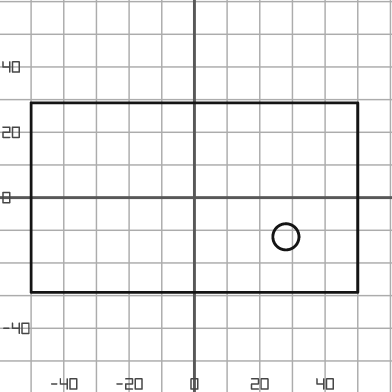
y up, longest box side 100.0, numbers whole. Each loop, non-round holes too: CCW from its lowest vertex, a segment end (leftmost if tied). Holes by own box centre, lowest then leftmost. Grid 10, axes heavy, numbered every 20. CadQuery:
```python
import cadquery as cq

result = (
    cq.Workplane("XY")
    .moveTo(-50.0, -29.0)
    .lineTo(50.0, -29.0)
    .lineTo(50.0, 29.0)
    .lineTo(-50.0, 29.0)
    .close()
    .moveTo(28.0, -12.0)
    .circle(4.0)
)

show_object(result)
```